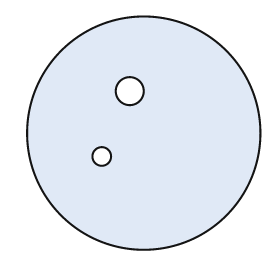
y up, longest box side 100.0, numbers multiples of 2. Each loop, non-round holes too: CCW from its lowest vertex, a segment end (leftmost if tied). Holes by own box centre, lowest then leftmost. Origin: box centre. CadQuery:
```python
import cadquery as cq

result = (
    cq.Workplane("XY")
    .moveTo(0.0, 0.0)
    .circle(50.0)
    .moveTo(-18.0, -10.0)
    .circle(4.0)
    .moveTo(-6.0, 18.0)
    .circle(6.0)
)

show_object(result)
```